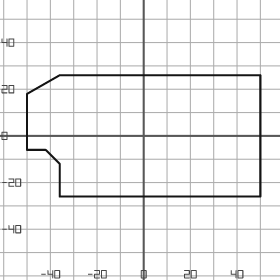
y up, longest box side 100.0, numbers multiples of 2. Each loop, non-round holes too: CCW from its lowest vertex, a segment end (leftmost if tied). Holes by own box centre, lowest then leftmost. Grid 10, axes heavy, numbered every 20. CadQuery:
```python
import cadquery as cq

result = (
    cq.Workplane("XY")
    .moveTo(-36.0, -26.0)
    .lineTo(50.0, -26.0)
    .lineTo(50.0, 26.0)
    .lineTo(-36.0, 26.0)
    .lineTo(-50.0, 18.0)
    .lineTo(-50.0, -6.0)
    .lineTo(-42.0, -6.0)
    .lineTo(-36.0, -12.0)
    .close()
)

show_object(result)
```